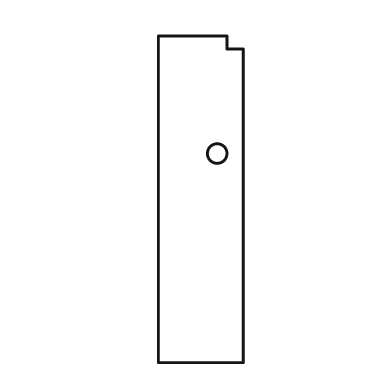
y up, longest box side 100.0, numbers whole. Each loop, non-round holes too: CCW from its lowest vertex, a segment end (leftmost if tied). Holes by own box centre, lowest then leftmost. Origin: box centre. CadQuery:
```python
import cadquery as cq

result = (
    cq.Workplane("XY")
    .moveTo(-13.0, -50.0)
    .lineTo(13.0, -50.0)
    .lineTo(13.0, 46.0)
    .lineTo(8.0, 46.0)
    .lineTo(8.0, 50.0)
    .lineTo(-13.0, 50.0)
    .close()
    .moveTo(5.0, 14.0)
    .circle(3.0)
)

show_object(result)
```